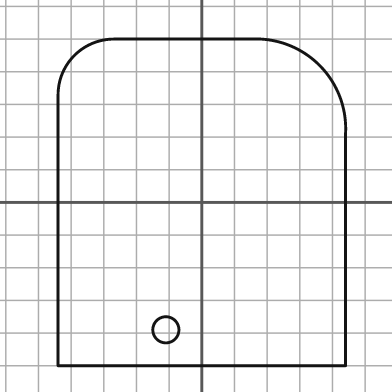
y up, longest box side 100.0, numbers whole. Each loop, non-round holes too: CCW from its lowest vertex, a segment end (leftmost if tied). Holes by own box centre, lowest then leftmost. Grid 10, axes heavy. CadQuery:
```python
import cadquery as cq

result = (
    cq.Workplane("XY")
    .moveTo(-44.0, -50.0)
    .lineTo(44.0, -50.0)
    .lineTo(44.0, 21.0)
    .threePointArc((36.0, 42.0), (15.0, 50.0))
    .lineTo(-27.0, 50.0)
    .threePointArc((-39.0, 45.0), (-44.0, 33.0))
    .close()
    .moveTo(-11.0, -39.0)
    .circle(4.0)
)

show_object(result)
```